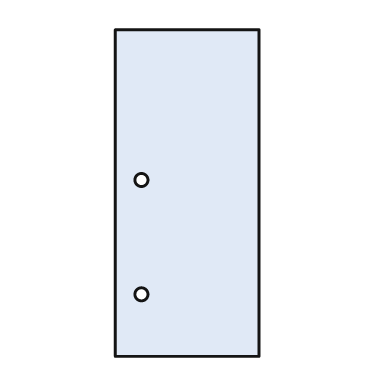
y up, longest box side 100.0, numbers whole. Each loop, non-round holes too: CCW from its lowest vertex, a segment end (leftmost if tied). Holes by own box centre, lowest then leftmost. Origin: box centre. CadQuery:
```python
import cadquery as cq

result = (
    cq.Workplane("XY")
    .moveTo(-22.0, -50.0)
    .lineTo(22.0, -50.0)
    .lineTo(22.0, 50.0)
    .lineTo(-22.0, 50.0)
    .close()
    .moveTo(-14.0, -31.0)
    .circle(2.0)
    .moveTo(-14.0, 4.0)
    .circle(2.0)
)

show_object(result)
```